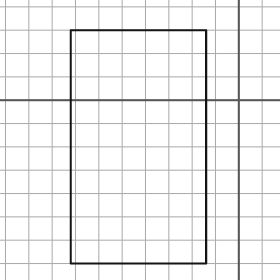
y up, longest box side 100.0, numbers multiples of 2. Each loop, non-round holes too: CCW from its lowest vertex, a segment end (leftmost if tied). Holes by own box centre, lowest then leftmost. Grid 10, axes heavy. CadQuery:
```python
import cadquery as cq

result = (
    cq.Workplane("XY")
    .moveTo(-72.0, -70.0)
    .lineTo(-14.0, -70.0)
    .lineTo(-14.0, 30.0)
    .lineTo(-72.0, 30.0)
    .close()
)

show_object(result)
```